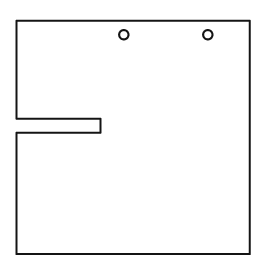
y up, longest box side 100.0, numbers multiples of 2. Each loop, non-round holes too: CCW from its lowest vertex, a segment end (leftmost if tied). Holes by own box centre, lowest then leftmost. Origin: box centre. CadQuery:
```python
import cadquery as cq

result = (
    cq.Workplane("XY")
    .moveTo(-50.0, -50.0)
    .lineTo(50.0, -50.0)
    .lineTo(50.0, 50.0)
    .lineTo(-50.0, 50.0)
    .lineTo(-50.0, 8.0)
    .lineTo(-14.0, 8.0)
    .lineTo(-14.0, 2.0)
    .lineTo(-50.0, 2.0)
    .close()
    .moveTo(-4.0, 44.0)
    .circle(2.0)
    .moveTo(32.0, 44.0)
    .circle(2.0)
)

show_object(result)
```